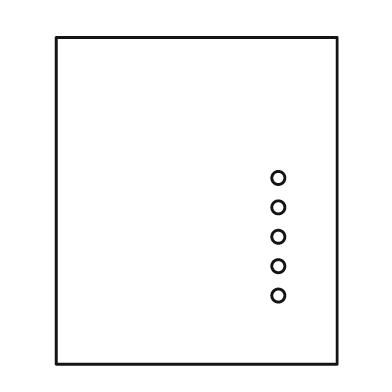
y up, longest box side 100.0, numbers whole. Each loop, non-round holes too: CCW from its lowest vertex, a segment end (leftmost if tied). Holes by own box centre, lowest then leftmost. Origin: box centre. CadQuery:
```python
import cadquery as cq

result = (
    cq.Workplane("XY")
    .moveTo(-43.0, -50.0)
    .lineTo(43.0, -50.0)
    .lineTo(43.0, 50.0)
    .lineTo(-43.0, 50.0)
    .close()
    .moveTo(25.0, -29.0)
    .circle(2.0)
    .moveTo(25.0, -20.0)
    .circle(2.0)
    .moveTo(25.0, -11.0)
    .circle(2.0)
    .moveTo(25.0, -2.0)
    .circle(2.0)
    .moveTo(25.0, 7.0)
    .circle(2.0)
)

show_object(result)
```